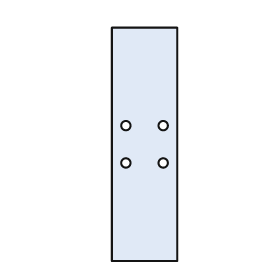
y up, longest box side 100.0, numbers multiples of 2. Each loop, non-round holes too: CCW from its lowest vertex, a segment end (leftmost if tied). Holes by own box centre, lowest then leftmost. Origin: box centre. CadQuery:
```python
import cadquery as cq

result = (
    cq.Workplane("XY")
    .moveTo(-14.0, -50.0)
    .lineTo(14.0, -50.0)
    .lineTo(14.0, 50.0)
    .lineTo(-14.0, 50.0)
    .close()
    .moveTo(-8.0, -8.0)
    .circle(2.0)
    .moveTo(8.0, -8.0)
    .circle(2.0)
    .moveTo(-8.0, 8.0)
    .circle(2.0)
    .moveTo(8.0, 8.0)
    .circle(2.0)
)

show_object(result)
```